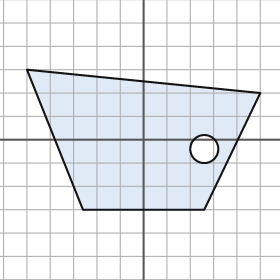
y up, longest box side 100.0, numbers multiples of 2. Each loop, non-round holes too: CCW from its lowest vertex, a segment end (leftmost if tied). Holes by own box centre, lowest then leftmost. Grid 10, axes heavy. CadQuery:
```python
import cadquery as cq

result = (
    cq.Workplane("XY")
    .moveTo(-26.0, -30.0)
    .lineTo(26.0, -30.0)
    .lineTo(50.0, 20.0)
    .lineTo(-50.0, 30.0)
    .close()
    .moveTo(26.0, -4.0)
    .circle(6.0)
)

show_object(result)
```